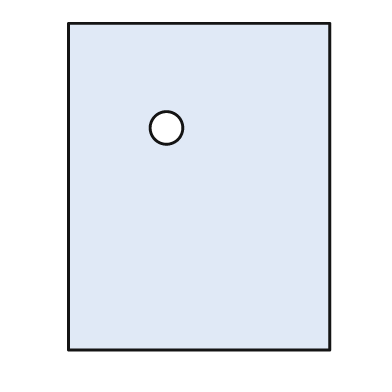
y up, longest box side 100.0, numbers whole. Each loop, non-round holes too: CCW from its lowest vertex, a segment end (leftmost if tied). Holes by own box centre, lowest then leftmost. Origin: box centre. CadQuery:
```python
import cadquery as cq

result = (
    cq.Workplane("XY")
    .moveTo(-40.0, -50.0)
    .lineTo(40.0, -50.0)
    .lineTo(40.0, 50.0)
    .lineTo(-40.0, 50.0)
    .close()
    .moveTo(-10.0, 18.0)
    .circle(5.0)
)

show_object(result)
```